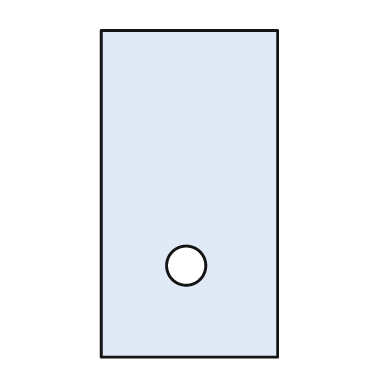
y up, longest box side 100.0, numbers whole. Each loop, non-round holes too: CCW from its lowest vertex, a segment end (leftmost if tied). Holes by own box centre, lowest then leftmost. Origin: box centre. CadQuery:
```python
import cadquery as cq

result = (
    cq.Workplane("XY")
    .moveTo(-27.0, -50.0)
    .lineTo(27.0, -50.0)
    .lineTo(27.0, 50.0)
    .lineTo(-27.0, 50.0)
    .close()
    .moveTo(-1.0, -22.0)
    .circle(6.0)
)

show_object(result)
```